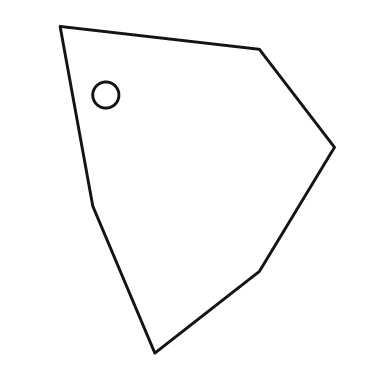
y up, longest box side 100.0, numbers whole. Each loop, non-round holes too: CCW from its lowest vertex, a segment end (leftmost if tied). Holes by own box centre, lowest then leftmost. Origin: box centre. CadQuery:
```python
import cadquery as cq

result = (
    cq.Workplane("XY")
    .moveTo(-13.0, -50.0)
    .lineTo(19.0, -25.0)
    .lineTo(42.0, 13.0)
    .lineTo(19.0, 43.0)
    .lineTo(-42.0, 50.0)
    .lineTo(-32.0, -5.0)
    .close()
    .moveTo(-28.0, 29.0)
    .circle(4.0)
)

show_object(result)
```